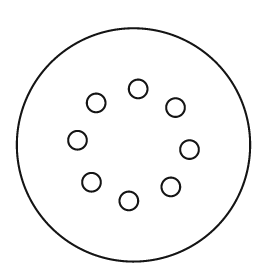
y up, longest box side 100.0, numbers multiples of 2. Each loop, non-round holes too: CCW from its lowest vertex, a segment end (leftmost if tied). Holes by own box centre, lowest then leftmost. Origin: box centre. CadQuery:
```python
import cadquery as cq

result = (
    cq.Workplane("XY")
    .moveTo(0.0, 0.0)
    .circle(50.0)
    .moveTo(-2.0, -24.0)
    .circle(4.0)
    .moveTo(16.0, -18.0)
    .circle(4.0)
    .moveTo(-18.0, -16.0)
    .circle(4.0)
    .moveTo(24.0, -2.0)
    .circle(4.0)
    .moveTo(-24.0, 2.0)
    .circle(4.0)
    .moveTo(18.0, 16.0)
    .circle(4.0)
    .moveTo(-16.0, 18.0)
    .circle(4.0)
    .moveTo(2.0, 24.0)
    .circle(4.0)
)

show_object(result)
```